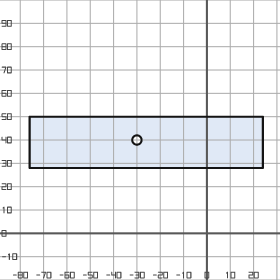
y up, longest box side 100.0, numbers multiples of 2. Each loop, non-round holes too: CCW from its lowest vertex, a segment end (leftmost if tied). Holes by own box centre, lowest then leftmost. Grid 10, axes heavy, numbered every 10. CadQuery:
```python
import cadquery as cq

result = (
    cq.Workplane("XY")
    .moveTo(-76.0, 28.0)
    .lineTo(24.0, 28.0)
    .lineTo(24.0, 50.0)
    .lineTo(-76.0, 50.0)
    .close()
    .moveTo(-30.0, 40.0)
    .circle(2.0)
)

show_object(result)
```